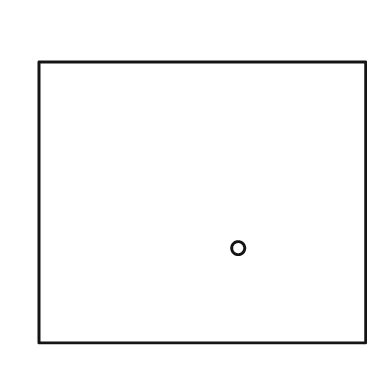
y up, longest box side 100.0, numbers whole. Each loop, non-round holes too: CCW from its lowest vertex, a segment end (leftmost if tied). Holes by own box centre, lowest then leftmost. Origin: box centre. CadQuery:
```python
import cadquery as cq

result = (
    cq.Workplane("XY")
    .moveTo(-50.0, -43.0)
    .lineTo(50.0, -43.0)
    .lineTo(50.0, 43.0)
    .lineTo(-50.0, 43.0)
    .close()
    .moveTo(11.0, -14.0)
    .circle(2.0)
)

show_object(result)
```